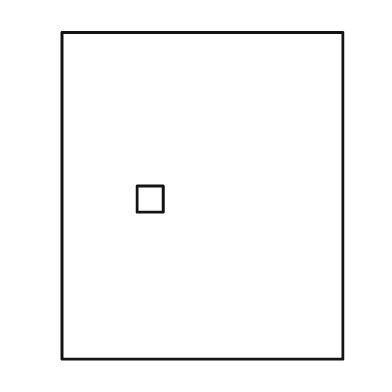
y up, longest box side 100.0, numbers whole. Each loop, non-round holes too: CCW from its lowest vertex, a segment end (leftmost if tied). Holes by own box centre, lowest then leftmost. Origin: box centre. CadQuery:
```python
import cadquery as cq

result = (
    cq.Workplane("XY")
    .moveTo(-43.0, -50.0)
    .lineTo(43.0, -50.0)
    .lineTo(43.0, 50.0)
    .lineTo(-43.0, 50.0)
    .close()
    .moveTo(-20.0, -5.0)
    .lineTo(-12.0, -5.0)
    .lineTo(-12.0, 3.0)
    .lineTo(-20.0, 3.0)
    .close()
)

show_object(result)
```